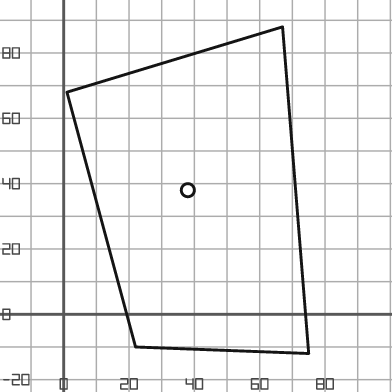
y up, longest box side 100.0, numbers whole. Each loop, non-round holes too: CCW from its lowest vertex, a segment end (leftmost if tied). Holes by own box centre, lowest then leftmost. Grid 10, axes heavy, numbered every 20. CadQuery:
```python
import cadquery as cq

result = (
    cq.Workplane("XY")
    .moveTo(75.0, -12.0)
    .lineTo(67.0, 88.0)
    .lineTo(1.0, 68.0)
    .lineTo(22.0, -10.0)
    .close()
    .moveTo(38.0, 38.0)
    .circle(2.0)
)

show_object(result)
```